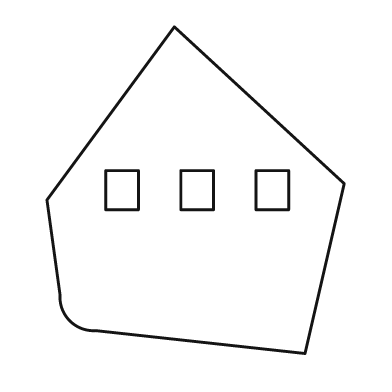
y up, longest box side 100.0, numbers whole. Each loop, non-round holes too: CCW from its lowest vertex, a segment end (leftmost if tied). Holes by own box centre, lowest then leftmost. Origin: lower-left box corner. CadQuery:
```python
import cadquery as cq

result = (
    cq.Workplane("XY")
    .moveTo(79.0, 0.0)
    .lineTo(91.0, 52.0)
    .lineTo(39.0, 100.0)
    .lineTo(0.0, 47.0)
    .lineTo(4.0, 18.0)
    .threePointArc((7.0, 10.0), (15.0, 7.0))
    .close()
    .moveTo(18.0, 44.0)
    .lineTo(28.0, 44.0)
    .lineTo(28.0, 56.0)
    .lineTo(18.0, 56.0)
    .close()
    .moveTo(41.0, 44.0)
    .lineTo(51.0, 44.0)
    .lineTo(51.0, 56.0)
    .lineTo(41.0, 56.0)
    .close()
    .moveTo(64.0, 44.0)
    .lineTo(74.0, 44.0)
    .lineTo(74.0, 56.0)
    .lineTo(64.0, 56.0)
    .close()
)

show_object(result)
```